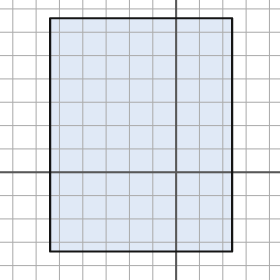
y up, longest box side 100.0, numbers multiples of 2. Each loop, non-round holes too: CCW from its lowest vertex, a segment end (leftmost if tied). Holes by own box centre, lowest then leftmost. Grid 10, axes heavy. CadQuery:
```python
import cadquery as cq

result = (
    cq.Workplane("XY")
    .moveTo(-54.0, -34.0)
    .lineTo(24.0, -34.0)
    .lineTo(24.0, 66.0)
    .lineTo(-54.0, 66.0)
    .close()
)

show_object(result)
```